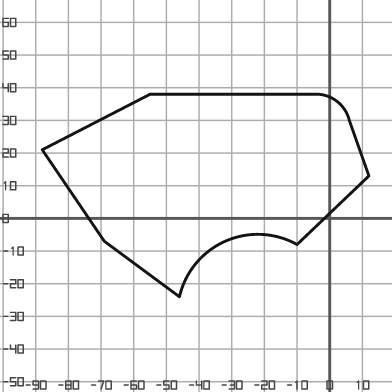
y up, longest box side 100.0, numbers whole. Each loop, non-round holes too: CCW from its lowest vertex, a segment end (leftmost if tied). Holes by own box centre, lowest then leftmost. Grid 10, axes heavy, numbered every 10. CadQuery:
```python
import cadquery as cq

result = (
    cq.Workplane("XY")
    .moveTo(-46.0, -24.0)
    .threePointArc((-32.0, -7.0), (-10.0, -8.0))
    .lineTo(12.0, 13.0)
    .lineTo(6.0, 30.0)
    .threePointArc((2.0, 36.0), (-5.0, 38.0))
    .lineTo(-55.0, 38.0)
    .lineTo(-88.0, 21.0)
    .lineTo(-69.0, -7.0)
    .close()
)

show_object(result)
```